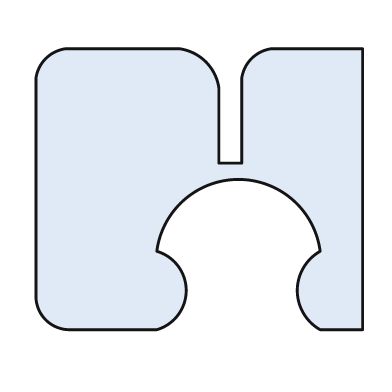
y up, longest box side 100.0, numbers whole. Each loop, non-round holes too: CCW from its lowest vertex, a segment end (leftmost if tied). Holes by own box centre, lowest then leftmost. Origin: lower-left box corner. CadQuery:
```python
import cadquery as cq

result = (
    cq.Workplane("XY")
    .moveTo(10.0, 0.0)
    .lineTo(37.0, 0.0)
    .threePointArc((46.0, 12.0), (37.0, 24.0))
    .threePointArc((62.0, 46.0), (87.0, 24.0))
    .threePointArc((80.0, 12.0), (87.0, 0.0))
    .lineTo(100.0, 0.0)
    .lineTo(100.0, 86.0)
    .lineTo(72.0, 86.0)
    .threePointArc((66.0, 83.0), (63.0, 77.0))
    .lineTo(63.0, 51.0)
    .lineTo(56.0, 51.0)
    .lineTo(56.0, 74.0)
    .threePointArc((52.0, 82.0), (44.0, 86.0))
    .lineTo(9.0, 86.0)
    .threePointArc((3.0, 83.0), (0.0, 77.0))
    .lineTo(0.0, 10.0)
    .threePointArc((3.0, 3.0), (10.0, 0.0))
    .close()
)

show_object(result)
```